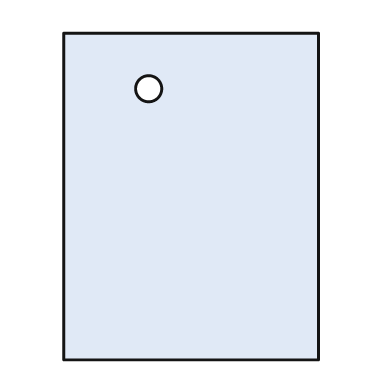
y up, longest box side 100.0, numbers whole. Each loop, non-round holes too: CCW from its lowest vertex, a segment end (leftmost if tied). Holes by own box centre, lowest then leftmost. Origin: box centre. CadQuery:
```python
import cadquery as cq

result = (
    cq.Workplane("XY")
    .moveTo(-39.0, -50.0)
    .lineTo(39.0, -50.0)
    .lineTo(39.0, 50.0)
    .lineTo(-39.0, 50.0)
    .close()
    .moveTo(-13.0, 33.0)
    .circle(4.0)
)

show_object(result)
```